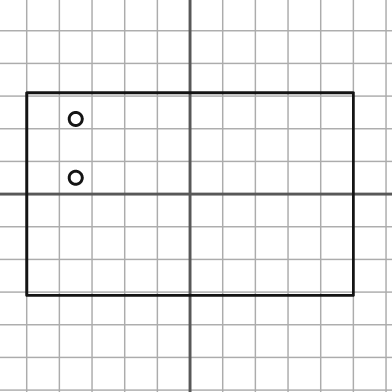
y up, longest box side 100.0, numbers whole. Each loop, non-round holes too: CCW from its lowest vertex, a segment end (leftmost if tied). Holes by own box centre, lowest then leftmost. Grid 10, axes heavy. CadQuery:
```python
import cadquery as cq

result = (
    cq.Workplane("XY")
    .moveTo(-50.0, -31.0)
    .lineTo(50.0, -31.0)
    .lineTo(50.0, 31.0)
    .lineTo(-50.0, 31.0)
    .close()
    .moveTo(-35.0, 5.0)
    .circle(2.0)
    .moveTo(-35.0, 23.0)
    .circle(2.0)
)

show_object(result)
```